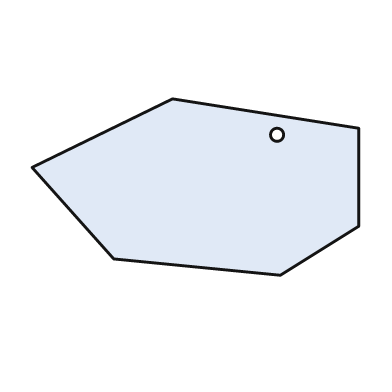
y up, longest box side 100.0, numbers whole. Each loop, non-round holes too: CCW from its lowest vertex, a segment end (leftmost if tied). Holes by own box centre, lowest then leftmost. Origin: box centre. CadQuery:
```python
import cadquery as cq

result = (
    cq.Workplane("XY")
    .moveTo(26.0, -27.0)
    .lineTo(50.0, -12.0)
    .lineTo(50.0, 18.0)
    .lineTo(-7.0, 27.0)
    .lineTo(-50.0, 6.0)
    .lineTo(-25.0, -22.0)
    .close()
    .moveTo(25.0, 16.0)
    .circle(2.0)
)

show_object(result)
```